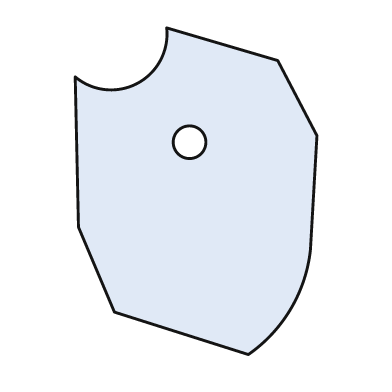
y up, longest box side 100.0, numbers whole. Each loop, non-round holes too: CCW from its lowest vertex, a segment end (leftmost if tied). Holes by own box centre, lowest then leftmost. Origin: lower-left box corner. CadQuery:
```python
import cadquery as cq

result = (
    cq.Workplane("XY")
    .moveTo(53.0, 0.0)
    .threePointArc((66.0, 14.0), (72.0, 32.0))
    .lineTo(74.0, 67.0)
    .lineTo(62.0, 90.0)
    .lineTo(28.0, 100.0)
    .threePointArc((19.0, 83.0), (0.0, 85.0))
    .lineTo(1.0, 39.0)
    .lineTo(12.0, 13.0)
    .close()
    .moveTo(35.0, 65.0)
    .circle(5.0)
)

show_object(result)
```